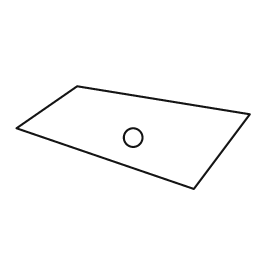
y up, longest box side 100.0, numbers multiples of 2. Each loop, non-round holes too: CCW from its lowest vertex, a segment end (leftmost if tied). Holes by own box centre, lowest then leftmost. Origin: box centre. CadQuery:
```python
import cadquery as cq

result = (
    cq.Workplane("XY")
    .moveTo(26.0, -22.0)
    .lineTo(50.0, 10.0)
    .lineTo(-24.0, 22.0)
    .lineTo(-50.0, 4.0)
    .close()
    .moveTo(0.0, 0.0)
    .circle(4.0)
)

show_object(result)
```